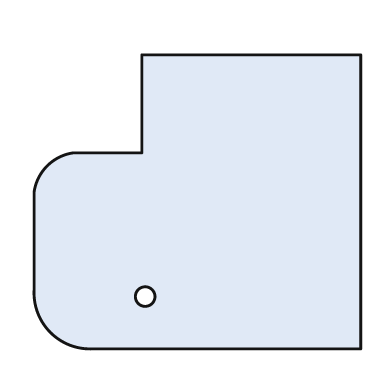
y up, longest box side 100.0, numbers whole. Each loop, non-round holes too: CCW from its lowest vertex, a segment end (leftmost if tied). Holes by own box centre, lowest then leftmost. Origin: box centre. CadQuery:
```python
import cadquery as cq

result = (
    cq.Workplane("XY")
    .moveTo(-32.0, -45.0)
    .lineTo(50.0, -45.0)
    .lineTo(50.0, 45.0)
    .lineTo(-17.0, 45.0)
    .lineTo(-17.0, 15.0)
    .lineTo(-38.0, 15.0)
    .threePointArc((-46.0, 11.0), (-50.0, 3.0))
    .lineTo(-50.0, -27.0)
    .threePointArc((-45.0, -40.0), (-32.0, -45.0))
    .close()
    .moveTo(-16.0, -29.0)
    .circle(3.0)
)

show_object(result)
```